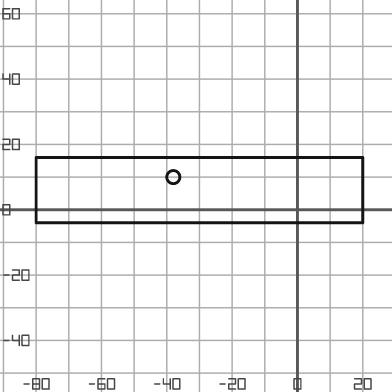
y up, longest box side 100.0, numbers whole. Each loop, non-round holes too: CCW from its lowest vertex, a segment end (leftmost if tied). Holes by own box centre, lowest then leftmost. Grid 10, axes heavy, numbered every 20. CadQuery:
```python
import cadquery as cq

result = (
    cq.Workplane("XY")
    .moveTo(-80.0, -4.0)
    .lineTo(20.0, -4.0)
    .lineTo(20.0, 16.0)
    .lineTo(-80.0, 16.0)
    .close()
    .moveTo(-38.0, 10.0)
    .circle(2.0)
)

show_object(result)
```